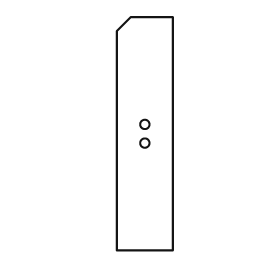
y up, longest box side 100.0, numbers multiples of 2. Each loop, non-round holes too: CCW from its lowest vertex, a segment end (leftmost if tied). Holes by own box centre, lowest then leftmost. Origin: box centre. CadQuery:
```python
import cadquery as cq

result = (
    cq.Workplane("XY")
    .moveTo(-12.0, -50.0)
    .lineTo(12.0, -50.0)
    .lineTo(12.0, 50.0)
    .lineTo(-6.0, 50.0)
    .lineTo(-12.0, 44.0)
    .close()
    .moveTo(0.0, -4.0)
    .circle(2.0)
    .moveTo(0.0, 4.0)
    .circle(2.0)
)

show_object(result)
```